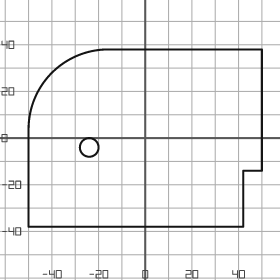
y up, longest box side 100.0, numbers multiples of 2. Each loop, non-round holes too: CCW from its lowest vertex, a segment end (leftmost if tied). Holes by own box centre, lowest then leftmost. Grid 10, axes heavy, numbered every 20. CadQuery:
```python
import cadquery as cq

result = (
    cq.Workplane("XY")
    .moveTo(-50.0, -38.0)
    .lineTo(42.0, -38.0)
    .lineTo(42.0, -14.0)
    .lineTo(50.0, -14.0)
    .lineTo(50.0, 38.0)
    .lineTo(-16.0, 38.0)
    .threePointArc((-40.0, 28.0), (-50.0, 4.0))
    .close()
    .moveTo(-24.0, -4.0)
    .circle(4.0)
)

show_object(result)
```